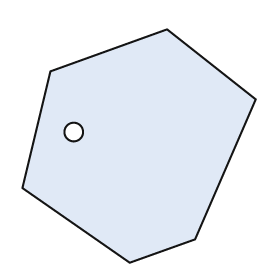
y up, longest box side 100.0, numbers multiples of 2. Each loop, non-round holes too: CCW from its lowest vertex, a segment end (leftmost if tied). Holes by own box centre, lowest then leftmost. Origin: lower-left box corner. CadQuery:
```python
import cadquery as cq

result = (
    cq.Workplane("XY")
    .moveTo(46.0, 0.0)
    .lineTo(74.0, 10.0)
    .lineTo(100.0, 70.0)
    .lineTo(62.0, 100.0)
    .lineTo(12.0, 82.0)
    .lineTo(0.0, 32.0)
    .close()
    .moveTo(22.0, 56.0)
    .circle(4.0)
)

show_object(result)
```